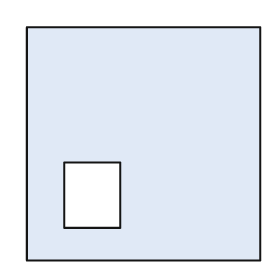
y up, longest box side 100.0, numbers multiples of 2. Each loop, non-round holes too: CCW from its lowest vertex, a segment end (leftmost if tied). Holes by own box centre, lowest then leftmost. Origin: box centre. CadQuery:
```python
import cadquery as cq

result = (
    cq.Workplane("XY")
    .moveTo(-50.0, -50.0)
    .lineTo(50.0, -50.0)
    .lineTo(50.0, 50.0)
    .lineTo(-50.0, 50.0)
    .close()
    .moveTo(-34.0, -36.0)
    .lineTo(-10.0, -36.0)
    .lineTo(-10.0, -8.0)
    .lineTo(-34.0, -8.0)
    .close()
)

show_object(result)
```